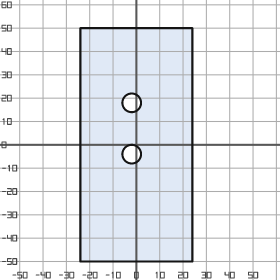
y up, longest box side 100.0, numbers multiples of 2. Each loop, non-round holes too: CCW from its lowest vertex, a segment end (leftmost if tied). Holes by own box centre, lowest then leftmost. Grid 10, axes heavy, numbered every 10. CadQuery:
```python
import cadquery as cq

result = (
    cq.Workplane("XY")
    .moveTo(-24.0, -50.0)
    .lineTo(24.0, -50.0)
    .lineTo(24.0, 50.0)
    .lineTo(-24.0, 50.0)
    .close()
    .moveTo(-2.0, -4.0)
    .circle(4.0)
    .moveTo(-2.0, 18.0)
    .circle(4.0)
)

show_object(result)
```